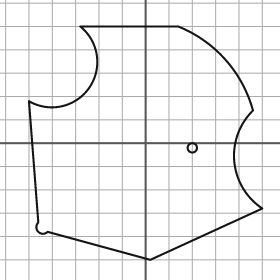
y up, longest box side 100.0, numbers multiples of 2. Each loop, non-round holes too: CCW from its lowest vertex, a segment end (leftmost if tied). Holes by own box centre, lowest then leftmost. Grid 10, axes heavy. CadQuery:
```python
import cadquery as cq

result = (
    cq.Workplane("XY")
    .moveTo(2.0, -50.0)
    .lineTo(50.0, -28.0)
    .threePointArc((38.0, -8.0), (46.0, 14.0))
    .threePointArc((34.0, 36.0), (14.0, 50.0))
    .lineTo(-28.0, 50.0)
    .threePointArc((-24.0, 24.0), (-50.0, 18.0))
    .lineTo(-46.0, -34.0)
    .threePointArc((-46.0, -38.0), (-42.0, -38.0))
    .close()
    .moveTo(20.0, -2.0)
    .circle(2.0)
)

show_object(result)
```